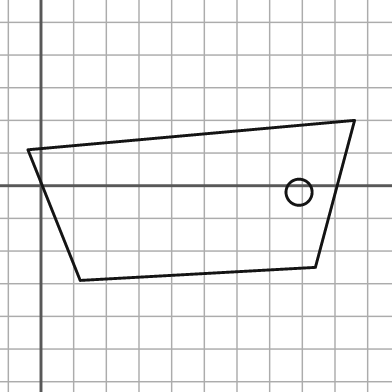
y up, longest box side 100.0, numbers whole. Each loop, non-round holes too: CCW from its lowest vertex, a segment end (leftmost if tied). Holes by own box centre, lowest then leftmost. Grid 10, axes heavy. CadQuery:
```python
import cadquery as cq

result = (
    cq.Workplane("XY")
    .moveTo(12.0, -29.0)
    .lineTo(84.0, -25.0)
    .lineTo(96.0, 20.0)
    .lineTo(-4.0, 11.0)
    .close()
    .moveTo(79.0, -2.0)
    .circle(4.0)
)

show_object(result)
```